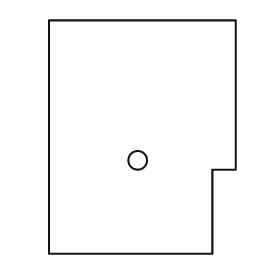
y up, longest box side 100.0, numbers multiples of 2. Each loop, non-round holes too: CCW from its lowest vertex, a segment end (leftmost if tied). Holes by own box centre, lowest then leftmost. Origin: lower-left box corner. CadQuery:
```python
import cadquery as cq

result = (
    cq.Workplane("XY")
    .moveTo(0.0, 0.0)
    .lineTo(70.0, 0.0)
    .lineTo(70.0, 36.0)
    .lineTo(80.0, 36.0)
    .lineTo(80.0, 100.0)
    .lineTo(0.0, 100.0)
    .close()
    .moveTo(38.0, 40.0)
    .circle(4.0)
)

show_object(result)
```